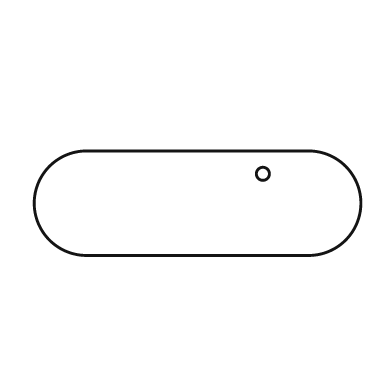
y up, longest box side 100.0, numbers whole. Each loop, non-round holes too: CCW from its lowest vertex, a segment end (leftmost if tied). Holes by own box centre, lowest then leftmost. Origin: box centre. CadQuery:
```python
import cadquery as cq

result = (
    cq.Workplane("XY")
    .moveTo(-34.0, -16.0)
    .lineTo(34.0, -16.0)
    .threePointArc((50.0, 0.0), (34.0, 16.0))
    .lineTo(-34.0, 16.0)
    .threePointArc((-50.0, 0.0), (-34.0, -16.0))
    .close()
    .moveTo(20.0, 9.0)
    .circle(2.0)
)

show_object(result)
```